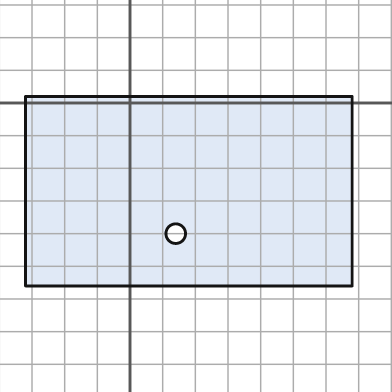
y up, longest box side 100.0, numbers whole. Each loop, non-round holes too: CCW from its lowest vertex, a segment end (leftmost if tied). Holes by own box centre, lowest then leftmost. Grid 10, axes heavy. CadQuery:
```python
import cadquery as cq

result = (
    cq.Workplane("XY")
    .moveTo(-32.0, -56.0)
    .lineTo(68.0, -56.0)
    .lineTo(68.0, 2.0)
    .lineTo(-32.0, 2.0)
    .close()
    .moveTo(14.0, -40.0)
    .circle(3.0)
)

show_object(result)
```